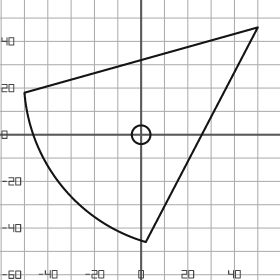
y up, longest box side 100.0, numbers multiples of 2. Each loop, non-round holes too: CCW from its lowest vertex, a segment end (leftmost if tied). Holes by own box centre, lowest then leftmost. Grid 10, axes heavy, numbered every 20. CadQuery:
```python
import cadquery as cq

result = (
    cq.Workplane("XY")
    .moveTo(2.0, -46.0)
    .lineTo(50.0, 46.0)
    .lineTo(-50.0, 18.0)
    .threePointArc((-34.0, -22.0), (2.0, -46.0))
    .close()
    .moveTo(0.0, 0.0)
    .circle(4.0)
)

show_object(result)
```